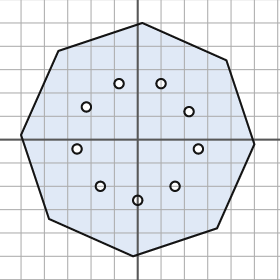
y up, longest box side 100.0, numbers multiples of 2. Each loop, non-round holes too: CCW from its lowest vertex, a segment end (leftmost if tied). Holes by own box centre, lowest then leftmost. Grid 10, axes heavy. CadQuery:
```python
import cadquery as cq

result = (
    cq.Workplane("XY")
    .moveTo(-2.0, -50.0)
    .lineTo(34.0, -38.0)
    .lineTo(50.0, -2.0)
    .lineTo(38.0, 34.0)
    .lineTo(2.0, 50.0)
    .lineTo(-34.0, 38.0)
    .lineTo(-50.0, 2.0)
    .lineTo(-38.0, -34.0)
    .close()
    .moveTo(0.0, -26.0)
    .circle(2.0)
    .moveTo(-16.0, -20.0)
    .circle(2.0)
    .moveTo(16.0, -20.0)
    .circle(2.0)
    .moveTo(-26.0, -4.0)
    .circle(2.0)
    .moveTo(26.0, -4.0)
    .circle(2.0)
    .moveTo(22.0, 12.0)
    .circle(2.0)
    .moveTo(-22.0, 14.0)
    .circle(2.0)
    .moveTo(-8.0, 24.0)
    .circle(2.0)
    .moveTo(10.0, 24.0)
    .circle(2.0)
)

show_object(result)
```